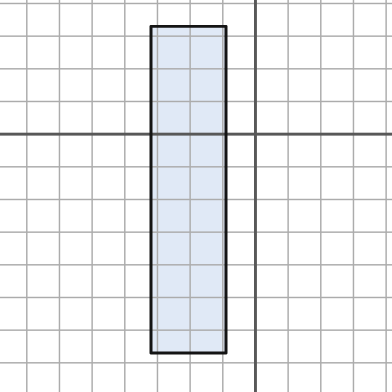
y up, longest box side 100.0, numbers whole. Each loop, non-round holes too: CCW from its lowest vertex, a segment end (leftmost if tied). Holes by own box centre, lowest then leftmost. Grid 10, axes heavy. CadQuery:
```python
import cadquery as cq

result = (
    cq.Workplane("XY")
    .moveTo(-32.0, -67.0)
    .lineTo(-9.0, -67.0)
    .lineTo(-9.0, 33.0)
    .lineTo(-32.0, 33.0)
    .close()
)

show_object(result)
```